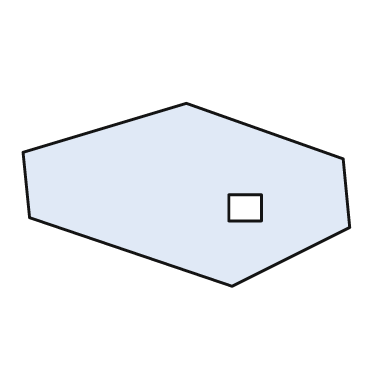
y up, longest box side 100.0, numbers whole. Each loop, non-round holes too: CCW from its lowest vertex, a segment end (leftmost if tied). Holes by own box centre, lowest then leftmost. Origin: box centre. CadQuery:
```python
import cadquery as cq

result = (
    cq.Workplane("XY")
    .moveTo(14.0, -28.0)
    .lineTo(50.0, -10.0)
    .lineTo(48.0, 11.0)
    .lineTo(0.0, 28.0)
    .lineTo(-50.0, 13.0)
    .lineTo(-48.0, -7.0)
    .close()
    .moveTo(13.0, -8.0)
    .lineTo(23.0, -8.0)
    .lineTo(23.0, 0.0)
    .lineTo(13.0, 0.0)
    .close()
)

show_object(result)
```